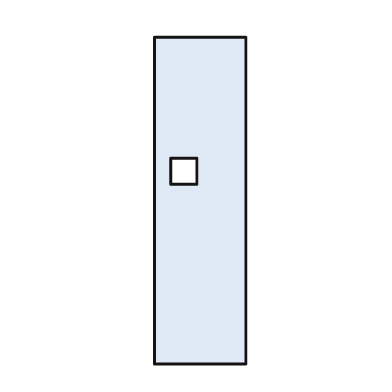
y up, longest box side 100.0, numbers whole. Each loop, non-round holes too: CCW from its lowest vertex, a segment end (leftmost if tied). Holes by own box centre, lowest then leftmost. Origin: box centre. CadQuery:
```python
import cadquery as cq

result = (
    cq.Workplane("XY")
    .moveTo(-14.0, -50.0)
    .lineTo(14.0, -50.0)
    .lineTo(14.0, 50.0)
    .lineTo(-14.0, 50.0)
    .close()
    .moveTo(-9.0, 5.0)
    .lineTo(-1.0, 5.0)
    .lineTo(-1.0, 13.0)
    .lineTo(-9.0, 13.0)
    .close()
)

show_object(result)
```